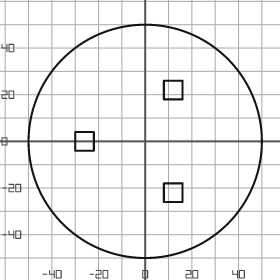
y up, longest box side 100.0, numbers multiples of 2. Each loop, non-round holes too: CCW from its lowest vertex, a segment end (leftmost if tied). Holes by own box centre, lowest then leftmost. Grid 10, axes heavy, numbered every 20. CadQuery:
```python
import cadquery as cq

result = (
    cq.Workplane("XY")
    .moveTo(0.0, 0.0)
    .circle(50.0)
    .moveTo(8.0, -26.0)
    .lineTo(16.0, -26.0)
    .lineTo(16.0, -18.0)
    .lineTo(8.0, -18.0)
    .close()
    .moveTo(-30.0, -4.0)
    .lineTo(-22.0, -4.0)
    .lineTo(-22.0, 4.0)
    .lineTo(-30.0, 4.0)
    .close()
    .moveTo(8.0, 18.0)
    .lineTo(16.0, 18.0)
    .lineTo(16.0, 26.0)
    .lineTo(8.0, 26.0)
    .close()
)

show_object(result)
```